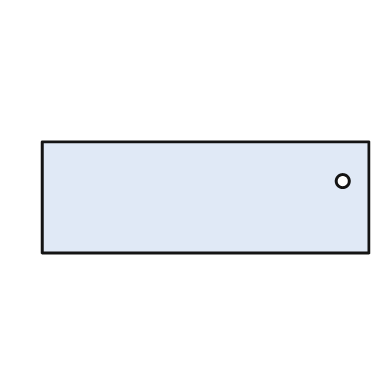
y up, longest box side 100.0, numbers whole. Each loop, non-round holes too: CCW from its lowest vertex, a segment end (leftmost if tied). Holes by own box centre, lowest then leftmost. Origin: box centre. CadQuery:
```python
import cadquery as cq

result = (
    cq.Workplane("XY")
    .moveTo(-50.0, -17.0)
    .lineTo(50.0, -17.0)
    .lineTo(50.0, 17.0)
    .lineTo(-50.0, 17.0)
    .close()
    .moveTo(42.0, 5.0)
    .circle(2.0)
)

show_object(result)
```